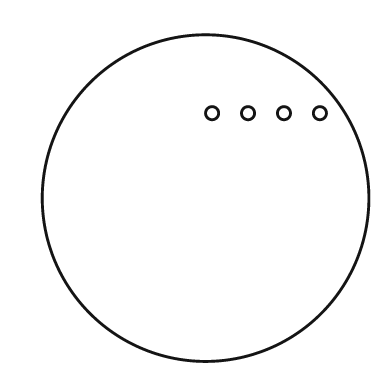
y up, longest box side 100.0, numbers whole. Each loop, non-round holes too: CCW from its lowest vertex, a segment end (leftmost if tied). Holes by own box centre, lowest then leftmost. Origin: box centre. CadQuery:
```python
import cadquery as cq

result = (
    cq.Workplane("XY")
    .moveTo(0.0, 0.0)
    .circle(50.0)
    .moveTo(2.0, 26.0)
    .circle(2.0)
    .moveTo(13.0, 26.0)
    .circle(2.0)
    .moveTo(24.0, 26.0)
    .circle(2.0)
    .moveTo(35.0, 26.0)
    .circle(2.0)
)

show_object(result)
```